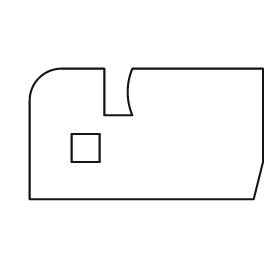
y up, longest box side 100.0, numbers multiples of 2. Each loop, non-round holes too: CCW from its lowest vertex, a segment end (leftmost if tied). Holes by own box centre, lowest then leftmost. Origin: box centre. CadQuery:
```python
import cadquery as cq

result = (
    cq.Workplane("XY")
    .moveTo(-50.0, -28.0)
    .lineTo(46.0, -28.0)
    .lineTo(50.0, -12.0)
    .lineTo(50.0, 28.0)
    .lineTo(-6.0, 28.0)
    .threePointArc((-8.0, 18.0), (-6.0, 8.0))
    .lineTo(-18.0, 8.0)
    .lineTo(-18.0, 28.0)
    .lineTo(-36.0, 28.0)
    .threePointArc((-46.0, 24.0), (-50.0, 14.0))
    .close()
    .moveTo(-32.0, -12.0)
    .lineTo(-20.0, -12.0)
    .lineTo(-20.0, 0.0)
    .lineTo(-32.0, 0.0)
    .close()
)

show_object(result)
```